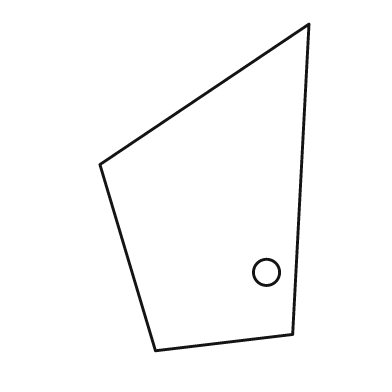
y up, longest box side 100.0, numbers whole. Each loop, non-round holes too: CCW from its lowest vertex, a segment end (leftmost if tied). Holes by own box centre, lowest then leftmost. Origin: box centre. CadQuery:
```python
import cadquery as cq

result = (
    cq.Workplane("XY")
    .moveTo(-15.0, -50.0)
    .lineTo(27.0, -45.0)
    .lineTo(32.0, 50.0)
    .lineTo(-32.0, 7.0)
    .close()
    .moveTo(19.0, -26.0)
    .circle(4.0)
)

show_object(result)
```